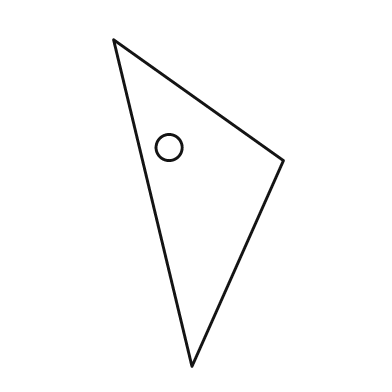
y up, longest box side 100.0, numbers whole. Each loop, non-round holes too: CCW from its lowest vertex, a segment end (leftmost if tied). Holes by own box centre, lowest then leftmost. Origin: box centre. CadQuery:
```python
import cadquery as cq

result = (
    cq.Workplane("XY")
    .moveTo(-2.0, -50.0)
    .lineTo(26.0, 13.0)
    .lineTo(-26.0, 50.0)
    .close()
    .moveTo(-9.0, 17.0)
    .circle(4.0)
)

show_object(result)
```